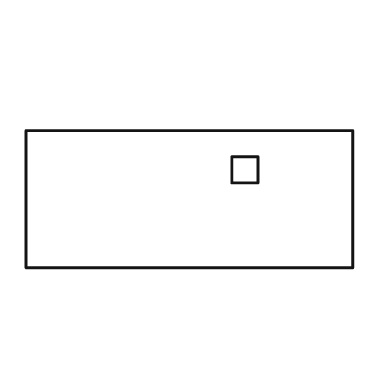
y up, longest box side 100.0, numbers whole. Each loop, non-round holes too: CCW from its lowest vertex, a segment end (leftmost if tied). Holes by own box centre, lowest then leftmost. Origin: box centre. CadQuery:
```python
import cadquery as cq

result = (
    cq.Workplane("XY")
    .moveTo(-50.0, -21.0)
    .lineTo(50.0, -21.0)
    .lineTo(50.0, 21.0)
    .lineTo(-50.0, 21.0)
    .close()
    .moveTo(13.0, 5.0)
    .lineTo(21.0, 5.0)
    .lineTo(21.0, 13.0)
    .lineTo(13.0, 13.0)
    .close()
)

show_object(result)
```